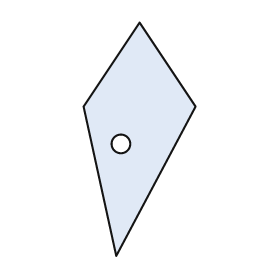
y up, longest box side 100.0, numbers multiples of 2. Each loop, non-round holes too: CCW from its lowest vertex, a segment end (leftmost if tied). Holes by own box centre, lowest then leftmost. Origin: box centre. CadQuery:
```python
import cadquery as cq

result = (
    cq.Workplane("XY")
    .moveTo(-10.0, -50.0)
    .lineTo(24.0, 14.0)
    .lineTo(0.0, 50.0)
    .lineTo(-24.0, 14.0)
    .close()
    .moveTo(-8.0, -2.0)
    .circle(4.0)
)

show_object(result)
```